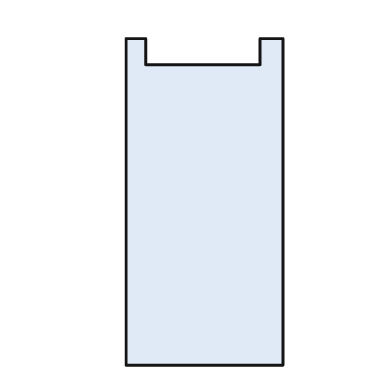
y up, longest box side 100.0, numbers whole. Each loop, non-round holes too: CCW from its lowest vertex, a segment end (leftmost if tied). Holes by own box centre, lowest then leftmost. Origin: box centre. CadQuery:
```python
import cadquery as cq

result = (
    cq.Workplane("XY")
    .moveTo(-24.0, -50.0)
    .lineTo(24.0, -50.0)
    .lineTo(24.0, 50.0)
    .lineTo(17.0, 50.0)
    .lineTo(17.0, 42.0)
    .lineTo(-18.0, 42.0)
    .lineTo(-18.0, 50.0)
    .lineTo(-24.0, 50.0)
    .close()
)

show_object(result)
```